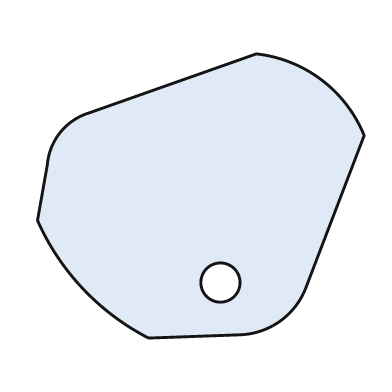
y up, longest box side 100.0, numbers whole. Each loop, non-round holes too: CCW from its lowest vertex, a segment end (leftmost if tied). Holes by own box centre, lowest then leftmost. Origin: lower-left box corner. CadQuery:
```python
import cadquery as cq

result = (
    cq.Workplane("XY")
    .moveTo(34.0, 0.0)
    .lineTo(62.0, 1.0)
    .threePointArc((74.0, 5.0), (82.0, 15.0))
    .lineTo(100.0, 62.0)
    .threePointArc((87.0, 79.0), (67.0, 87.0))
    .lineTo(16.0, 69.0)
    .threePointArc((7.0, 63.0), (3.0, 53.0))
    .lineTo(0.0, 36.0)
    .threePointArc((14.0, 15.0), (34.0, 0.0))
    .close()
    .moveTo(56.0, 17.0)
    .circle(6.0)
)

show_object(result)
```